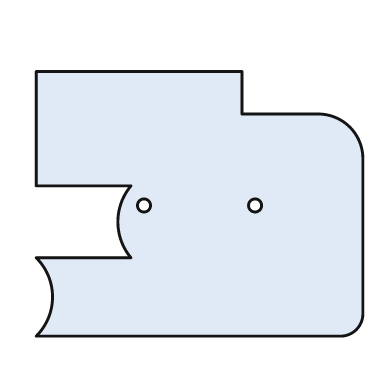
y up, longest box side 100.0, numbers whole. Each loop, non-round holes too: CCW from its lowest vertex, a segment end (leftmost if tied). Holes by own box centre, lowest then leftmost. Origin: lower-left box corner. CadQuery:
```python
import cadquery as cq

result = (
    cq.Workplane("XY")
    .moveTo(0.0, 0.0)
    .lineTo(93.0, 0.0)
    .threePointArc((98.0, 2.0), (100.0, 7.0))
    .lineTo(100.0, 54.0)
    .threePointArc((96.0, 64.0), (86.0, 68.0))
    .lineTo(63.0, 68.0)
    .lineTo(63.0, 81.0)
    .lineTo(0.0, 81.0)
    .lineTo(0.0, 46.0)
    .lineTo(29.0, 46.0)
    .threePointArc((25.0, 35.0), (29.0, 24.0))
    .lineTo(0.0, 24.0)
    .threePointArc((5.0, 12.0), (0.0, 0.0))
    .close()
    .moveTo(33.0, 40.0)
    .circle(2.0)
    .moveTo(67.0, 40.0)
    .circle(2.0)
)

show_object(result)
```